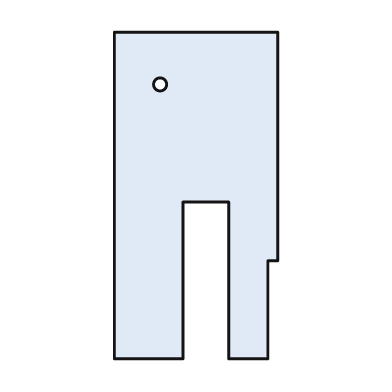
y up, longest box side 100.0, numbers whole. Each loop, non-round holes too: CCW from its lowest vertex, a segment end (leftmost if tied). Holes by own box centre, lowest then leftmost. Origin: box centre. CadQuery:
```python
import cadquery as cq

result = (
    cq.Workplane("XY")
    .moveTo(-25.0, -50.0)
    .lineTo(-4.0, -50.0)
    .lineTo(-4.0, -2.0)
    .lineTo(10.0, -2.0)
    .lineTo(10.0, -50.0)
    .lineTo(22.0, -50.0)
    .lineTo(22.0, -20.0)
    .lineTo(25.0, -20.0)
    .lineTo(25.0, 50.0)
    .lineTo(-25.0, 50.0)
    .close()
    .moveTo(-11.0, 34.0)
    .circle(2.0)
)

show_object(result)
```